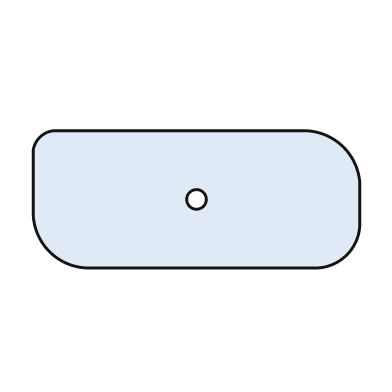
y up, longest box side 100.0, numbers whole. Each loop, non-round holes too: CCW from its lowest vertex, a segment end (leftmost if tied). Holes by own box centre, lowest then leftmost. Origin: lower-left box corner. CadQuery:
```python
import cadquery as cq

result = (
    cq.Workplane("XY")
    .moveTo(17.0, 0.0)
    .lineTo(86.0, 0.0)
    .threePointArc((96.0, 4.0), (100.0, 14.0))
    .lineTo(100.0, 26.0)
    .threePointArc((95.0, 37.0), (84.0, 42.0))
    .lineTo(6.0, 42.0)
    .threePointArc((2.0, 40.0), (0.0, 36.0))
    .lineTo(0.0, 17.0)
    .threePointArc((5.0, 5.0), (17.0, 0.0))
    .close()
    .moveTo(50.0, 21.0)
    .circle(3.0)
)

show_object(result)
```